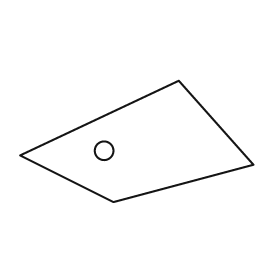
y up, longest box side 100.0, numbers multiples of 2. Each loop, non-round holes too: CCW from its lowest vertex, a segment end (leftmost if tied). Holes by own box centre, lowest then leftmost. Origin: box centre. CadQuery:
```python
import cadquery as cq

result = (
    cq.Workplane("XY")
    .moveTo(-10.0, -26.0)
    .lineTo(50.0, -10.0)
    .lineTo(18.0, 26.0)
    .lineTo(-50.0, -6.0)
    .close()
    .moveTo(-14.0, -4.0)
    .circle(4.0)
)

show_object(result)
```